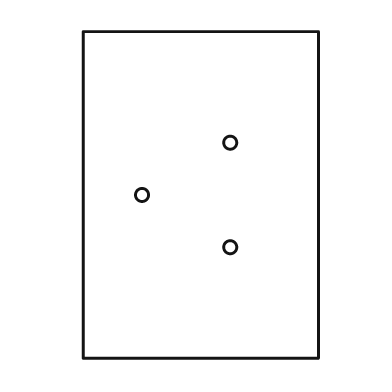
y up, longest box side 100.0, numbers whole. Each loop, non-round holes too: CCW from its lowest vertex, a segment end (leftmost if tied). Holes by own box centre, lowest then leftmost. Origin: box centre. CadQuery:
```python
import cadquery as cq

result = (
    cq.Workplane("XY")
    .moveTo(-36.0, -50.0)
    .lineTo(36.0, -50.0)
    .lineTo(36.0, 50.0)
    .lineTo(-36.0, 50.0)
    .close()
    .moveTo(9.0, -16.0)
    .circle(2.0)
    .moveTo(-18.0, 0.0)
    .circle(2.0)
    .moveTo(9.0, 16.0)
    .circle(2.0)
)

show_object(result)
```